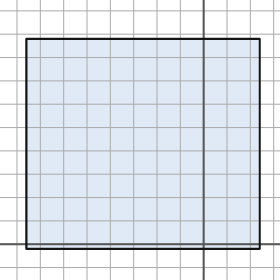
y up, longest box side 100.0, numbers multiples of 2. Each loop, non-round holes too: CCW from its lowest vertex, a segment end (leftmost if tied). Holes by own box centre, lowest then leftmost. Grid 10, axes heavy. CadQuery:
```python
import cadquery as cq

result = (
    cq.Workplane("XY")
    .moveTo(-76.0, -2.0)
    .lineTo(24.0, -2.0)
    .lineTo(24.0, 88.0)
    .lineTo(-76.0, 88.0)
    .close()
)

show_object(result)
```